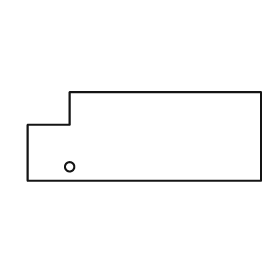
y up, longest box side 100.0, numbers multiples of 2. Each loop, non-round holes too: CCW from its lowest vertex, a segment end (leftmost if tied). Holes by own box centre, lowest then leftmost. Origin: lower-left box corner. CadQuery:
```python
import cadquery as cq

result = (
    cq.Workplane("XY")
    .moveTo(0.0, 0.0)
    .lineTo(100.0, 0.0)
    .lineTo(100.0, 38.0)
    .lineTo(18.0, 38.0)
    .lineTo(18.0, 24.0)
    .lineTo(0.0, 24.0)
    .close()
    .moveTo(18.0, 6.0)
    .circle(2.0)
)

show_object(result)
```